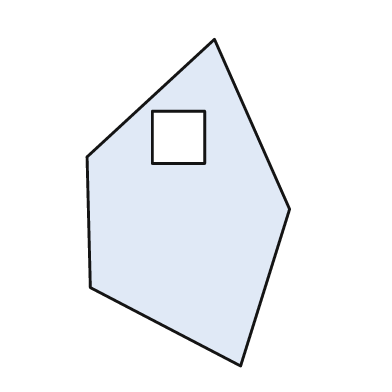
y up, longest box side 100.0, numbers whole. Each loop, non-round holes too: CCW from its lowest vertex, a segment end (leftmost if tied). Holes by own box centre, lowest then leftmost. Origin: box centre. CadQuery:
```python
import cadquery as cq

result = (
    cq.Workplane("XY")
    .moveTo(16.0, -50.0)
    .lineTo(31.0, -2.0)
    .lineTo(8.0, 50.0)
    .lineTo(-31.0, 14.0)
    .lineTo(-30.0, -26.0)
    .close()
    .moveTo(-11.0, 12.0)
    .lineTo(5.0, 12.0)
    .lineTo(5.0, 28.0)
    .lineTo(-11.0, 28.0)
    .close()
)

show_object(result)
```